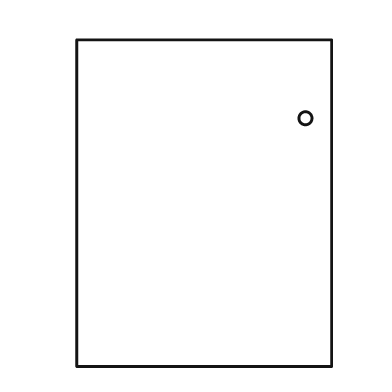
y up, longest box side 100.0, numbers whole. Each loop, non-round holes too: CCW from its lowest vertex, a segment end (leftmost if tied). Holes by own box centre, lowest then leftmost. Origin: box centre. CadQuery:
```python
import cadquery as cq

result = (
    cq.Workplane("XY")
    .moveTo(-39.0, -50.0)
    .lineTo(39.0, -50.0)
    .lineTo(39.0, 50.0)
    .lineTo(-39.0, 50.0)
    .close()
    .moveTo(31.0, 26.0)
    .circle(2.0)
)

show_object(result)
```